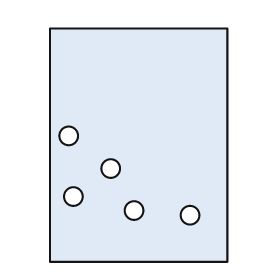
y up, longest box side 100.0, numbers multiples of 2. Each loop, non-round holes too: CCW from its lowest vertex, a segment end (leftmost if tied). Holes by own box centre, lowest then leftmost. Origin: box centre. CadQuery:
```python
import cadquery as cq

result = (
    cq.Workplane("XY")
    .moveTo(-38.0, -50.0)
    .lineTo(38.0, -50.0)
    .lineTo(38.0, 50.0)
    .lineTo(-38.0, 50.0)
    .close()
    .moveTo(22.0, -30.0)
    .circle(4.0)
    .moveTo(-2.0, -28.0)
    .circle(4.0)
    .moveTo(-28.0, -22.0)
    .circle(4.0)
    .moveTo(-12.0, -10.0)
    .circle(4.0)
    .moveTo(-30.0, 4.0)
    .circle(4.0)
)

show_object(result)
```